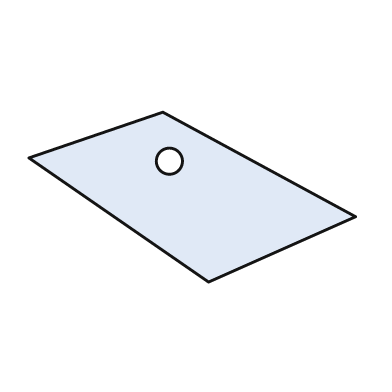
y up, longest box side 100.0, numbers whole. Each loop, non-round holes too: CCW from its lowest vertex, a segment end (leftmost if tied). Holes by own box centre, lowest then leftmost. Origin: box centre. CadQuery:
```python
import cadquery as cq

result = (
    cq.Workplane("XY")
    .moveTo(5.0, -26.0)
    .lineTo(50.0, -6.0)
    .lineTo(-9.0, 26.0)
    .lineTo(-50.0, 12.0)
    .close()
    .moveTo(-7.0, 11.0)
    .circle(4.0)
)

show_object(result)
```